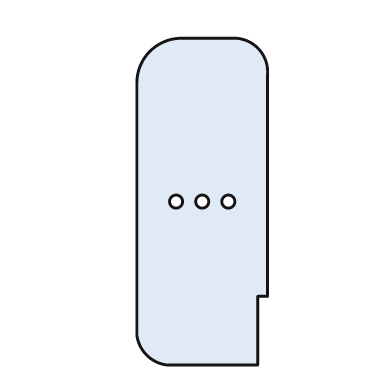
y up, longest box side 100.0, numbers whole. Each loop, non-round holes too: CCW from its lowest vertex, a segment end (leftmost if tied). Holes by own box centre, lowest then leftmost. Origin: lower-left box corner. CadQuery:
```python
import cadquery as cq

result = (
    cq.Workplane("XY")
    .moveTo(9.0, 0.0)
    .lineTo(37.0, 0.0)
    .lineTo(37.0, 21.0)
    .lineTo(40.0, 21.0)
    .lineTo(40.0, 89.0)
    .threePointArc((37.0, 97.0), (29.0, 100.0))
    .lineTo(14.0, 100.0)
    .threePointArc((4.0, 96.0), (0.0, 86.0))
    .lineTo(0.0, 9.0)
    .threePointArc((3.0, 3.0), (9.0, 0.0))
    .close()
    .moveTo(12.0, 50.0)
    .circle(2.0)
    .moveTo(20.0, 50.0)
    .circle(2.0)
    .moveTo(28.0, 50.0)
    .circle(2.0)
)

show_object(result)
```